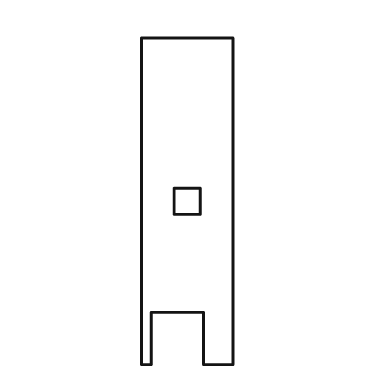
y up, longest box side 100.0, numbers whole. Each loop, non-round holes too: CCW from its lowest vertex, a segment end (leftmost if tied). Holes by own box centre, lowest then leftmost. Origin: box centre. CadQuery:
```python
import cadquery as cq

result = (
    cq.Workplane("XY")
    .moveTo(-14.0, -50.0)
    .lineTo(-11.0, -50.0)
    .lineTo(-11.0, -34.0)
    .lineTo(5.0, -34.0)
    .lineTo(5.0, -50.0)
    .lineTo(14.0, -50.0)
    .lineTo(14.0, 50.0)
    .lineTo(-14.0, 50.0)
    .close()
    .moveTo(-4.0, -4.0)
    .lineTo(4.0, -4.0)
    .lineTo(4.0, 4.0)
    .lineTo(-4.0, 4.0)
    .close()
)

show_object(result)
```